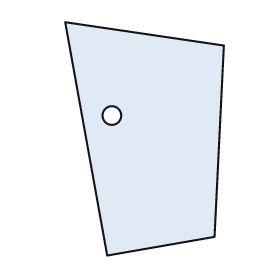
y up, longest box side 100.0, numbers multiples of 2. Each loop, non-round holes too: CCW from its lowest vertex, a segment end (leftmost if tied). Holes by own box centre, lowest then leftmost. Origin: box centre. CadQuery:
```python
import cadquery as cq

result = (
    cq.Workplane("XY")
    .moveTo(-16.0, -50.0)
    .lineTo(30.0, -42.0)
    .lineTo(34.0, 40.0)
    .lineTo(-34.0, 50.0)
    .close()
    .moveTo(-14.0, 10.0)
    .circle(4.0)
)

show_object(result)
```